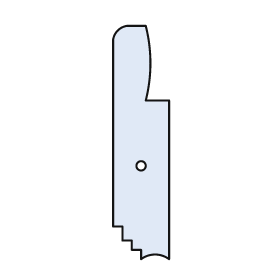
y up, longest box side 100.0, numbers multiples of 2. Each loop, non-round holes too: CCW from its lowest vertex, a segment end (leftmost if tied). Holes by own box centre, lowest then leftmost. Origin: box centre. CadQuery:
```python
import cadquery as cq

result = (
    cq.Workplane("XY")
    .moveTo(0.0, -50.0)
    .threePointArc((6.0, -48.0), (12.0, -50.0))
    .lineTo(12.0, 18.0)
    .lineTo(2.0, 18.0)
    .threePointArc((4.0, 34.0), (2.0, 50.0))
    .lineTo(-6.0, 50.0)
    .threePointArc((-10.0, 48.0), (-12.0, 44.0))
    .lineTo(-12.0, -36.0)
    .lineTo(-8.0, -36.0)
    .lineTo(-8.0, -42.0)
    .lineTo(-4.0, -42.0)
    .lineTo(-4.0, -46.0)
    .lineTo(0.0, -46.0)
    .close()
    .moveTo(0.0, -10.0)
    .circle(2.0)
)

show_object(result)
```